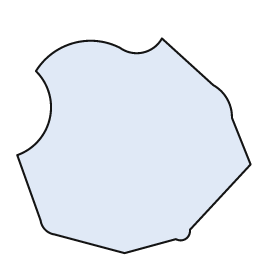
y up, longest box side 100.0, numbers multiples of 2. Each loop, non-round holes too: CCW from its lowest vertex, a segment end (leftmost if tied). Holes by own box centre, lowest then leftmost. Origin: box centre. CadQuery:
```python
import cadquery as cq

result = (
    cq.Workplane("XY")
    .moveTo(-4.0, -46.0)
    .lineTo(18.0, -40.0)
    .threePointArc((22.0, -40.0), (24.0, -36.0))
    .lineTo(50.0, -8.0)
    .lineTo(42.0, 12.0)
    .threePointArc((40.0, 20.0), (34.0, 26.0))
    .lineTo(12.0, 46.0)
    .threePointArc((4.0, 40.0), (-6.0, 42.0))
    .threePointArc((-26.0, 44.0), (-42.0, 32.0))
    .threePointArc((-36.0, 12.0), (-50.0, -4.0))
    .lineTo(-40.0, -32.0)
    .threePointArc((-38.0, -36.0), (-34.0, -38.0))
    .close()
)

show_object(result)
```